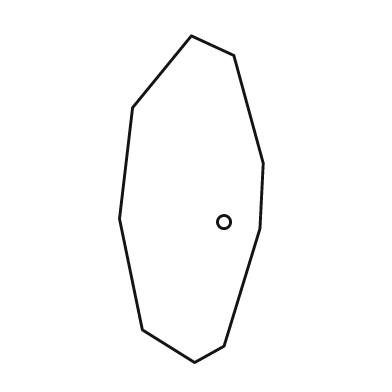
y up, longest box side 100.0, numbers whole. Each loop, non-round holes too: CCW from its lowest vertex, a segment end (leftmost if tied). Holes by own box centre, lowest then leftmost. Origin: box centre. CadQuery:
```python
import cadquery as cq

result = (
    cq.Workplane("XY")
    .moveTo(1.0, -50.0)
    .lineTo(10.0, -45.0)
    .lineTo(21.0, -9.0)
    .lineTo(22.0, 11.0)
    .lineTo(13.0, 44.0)
    .lineTo(0.0, 50.0)
    .lineTo(-18.0, 28.0)
    .lineTo(-22.0, -6.0)
    .lineTo(-15.0, -40.0)
    .close()
    .moveTo(10.0, -7.0)
    .circle(2.0)
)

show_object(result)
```